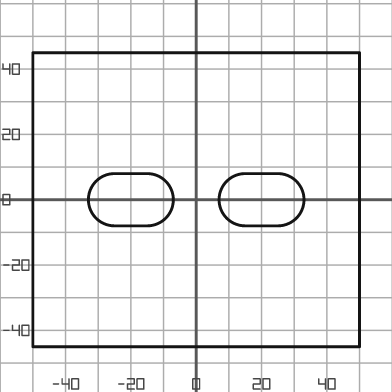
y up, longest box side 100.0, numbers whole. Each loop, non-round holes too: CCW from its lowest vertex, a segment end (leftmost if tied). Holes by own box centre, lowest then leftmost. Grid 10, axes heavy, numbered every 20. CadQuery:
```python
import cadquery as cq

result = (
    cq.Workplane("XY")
    .moveTo(-50.0, -45.0)
    .lineTo(50.0, -45.0)
    .lineTo(50.0, 45.0)
    .lineTo(-50.0, 45.0)
    .close()
    .moveTo(-25.0, -8.0)
    .lineTo(-15.0, -8.0)
    .threePointArc((-7.0, 0.0), (-15.0, 8.0))
    .lineTo(-25.0, 8.0)
    .threePointArc((-33.0, 0.0), (-25.0, -8.0))
    .close()
    .moveTo(15.0, -8.0)
    .lineTo(25.0, -8.0)
    .threePointArc((33.0, 0.0), (25.0, 8.0))
    .lineTo(15.0, 8.0)
    .threePointArc((7.0, 0.0), (15.0, -8.0))
    .close()
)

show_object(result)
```